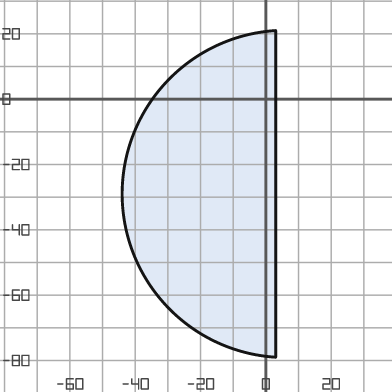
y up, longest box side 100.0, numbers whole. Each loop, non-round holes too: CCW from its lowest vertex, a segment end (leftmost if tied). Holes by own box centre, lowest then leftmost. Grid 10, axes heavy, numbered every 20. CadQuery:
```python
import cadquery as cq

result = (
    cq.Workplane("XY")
    .moveTo(3.0, -79.0)
    .lineTo(3.0, 21.0)
    .threePointArc((-44.0, -29.0), (3.0, -79.0))
    .close()
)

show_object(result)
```